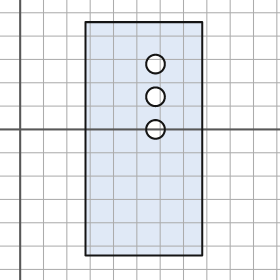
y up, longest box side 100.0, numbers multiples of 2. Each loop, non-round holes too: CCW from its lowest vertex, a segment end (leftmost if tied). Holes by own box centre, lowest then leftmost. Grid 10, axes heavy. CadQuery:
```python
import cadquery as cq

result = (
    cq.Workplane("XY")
    .moveTo(28.0, -54.0)
    .lineTo(78.0, -54.0)
    .lineTo(78.0, 46.0)
    .lineTo(28.0, 46.0)
    .close()
    .moveTo(58.0, 0.0)
    .circle(4.0)
    .moveTo(58.0, 14.0)
    .circle(4.0)
    .moveTo(58.0, 28.0)
    .circle(4.0)
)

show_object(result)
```